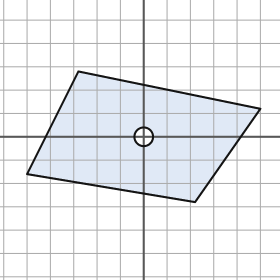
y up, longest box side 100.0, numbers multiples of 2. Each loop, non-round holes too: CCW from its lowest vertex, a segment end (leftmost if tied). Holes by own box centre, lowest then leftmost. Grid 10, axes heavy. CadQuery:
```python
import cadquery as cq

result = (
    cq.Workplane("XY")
    .moveTo(22.0, -28.0)
    .lineTo(50.0, 12.0)
    .lineTo(-28.0, 28.0)
    .lineTo(-50.0, -16.0)
    .close()
    .moveTo(0.0, 0.0)
    .circle(4.0)
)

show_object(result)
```